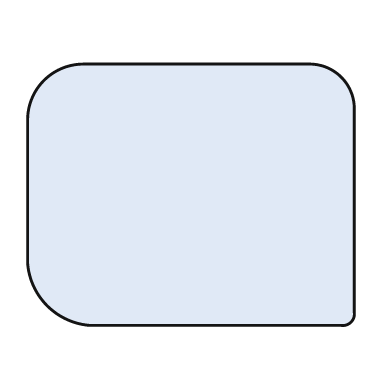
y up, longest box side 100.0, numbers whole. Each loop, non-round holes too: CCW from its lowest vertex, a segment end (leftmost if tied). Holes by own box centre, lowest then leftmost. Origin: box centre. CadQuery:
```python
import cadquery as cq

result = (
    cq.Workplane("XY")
    .moveTo(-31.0, -40.0)
    .lineTo(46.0, -40.0)
    .threePointArc((49.0, -39.0), (50.0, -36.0))
    .lineTo(50.0, 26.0)
    .threePointArc((46.0, 36.0), (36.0, 40.0))
    .lineTo(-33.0, 40.0)
    .threePointArc((-45.0, 35.0), (-50.0, 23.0))
    .lineTo(-50.0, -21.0)
    .threePointArc((-44.0, -34.0), (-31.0, -40.0))
    .close()
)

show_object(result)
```